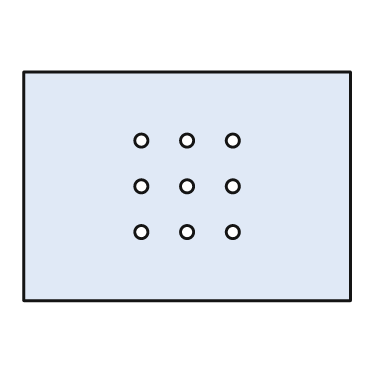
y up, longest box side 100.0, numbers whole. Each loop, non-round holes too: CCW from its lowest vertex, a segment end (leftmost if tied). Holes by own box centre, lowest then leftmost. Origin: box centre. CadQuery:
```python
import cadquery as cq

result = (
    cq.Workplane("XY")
    .moveTo(-50.0, -35.0)
    .lineTo(50.0, -35.0)
    .lineTo(50.0, 35.0)
    .lineTo(-50.0, 35.0)
    .close()
    .moveTo(-14.0, -14.0)
    .circle(2.0)
    .moveTo(0.0, -14.0)
    .circle(2.0)
    .moveTo(14.0, -14.0)
    .circle(2.0)
    .moveTo(-14.0, 0.0)
    .circle(2.0)
    .moveTo(0.0, 0.0)
    .circle(2.0)
    .moveTo(14.0, 0.0)
    .circle(2.0)
    .moveTo(-14.0, 14.0)
    .circle(2.0)
    .moveTo(0.0, 14.0)
    .circle(2.0)
    .moveTo(14.0, 14.0)
    .circle(2.0)
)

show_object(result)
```